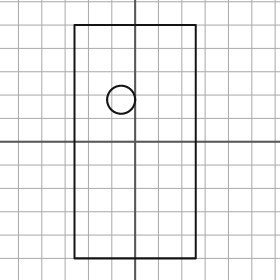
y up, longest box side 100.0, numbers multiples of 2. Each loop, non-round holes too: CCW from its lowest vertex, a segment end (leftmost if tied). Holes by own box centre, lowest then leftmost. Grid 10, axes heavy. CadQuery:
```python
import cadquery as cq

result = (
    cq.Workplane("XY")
    .moveTo(-26.0, -50.0)
    .lineTo(26.0, -50.0)
    .lineTo(26.0, 50.0)
    .lineTo(-26.0, 50.0)
    .close()
    .moveTo(-6.0, 18.0)
    .circle(6.0)
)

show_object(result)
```